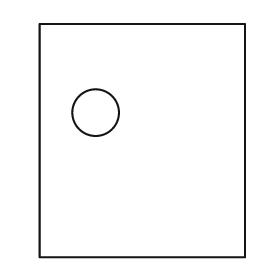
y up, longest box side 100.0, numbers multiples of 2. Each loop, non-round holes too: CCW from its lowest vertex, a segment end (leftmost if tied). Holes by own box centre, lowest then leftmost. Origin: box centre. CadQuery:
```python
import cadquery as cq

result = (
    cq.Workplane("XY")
    .moveTo(-44.0, -50.0)
    .lineTo(44.0, -50.0)
    .lineTo(44.0, 50.0)
    .lineTo(-44.0, 50.0)
    .close()
    .moveTo(-20.0, 12.0)
    .circle(10.0)
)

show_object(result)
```